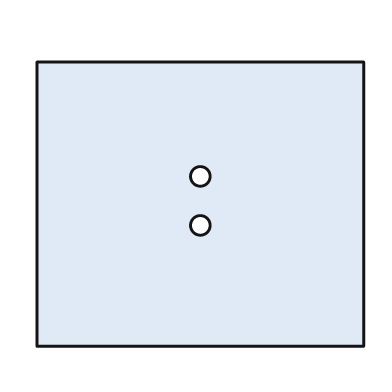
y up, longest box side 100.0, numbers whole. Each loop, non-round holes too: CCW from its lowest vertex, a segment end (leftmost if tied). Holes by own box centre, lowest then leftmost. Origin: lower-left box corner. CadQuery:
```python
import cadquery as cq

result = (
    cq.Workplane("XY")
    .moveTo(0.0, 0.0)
    .lineTo(100.0, 0.0)
    .lineTo(100.0, 87.0)
    .lineTo(0.0, 87.0)
    .close()
    .moveTo(50.0, 37.0)
    .circle(3.0)
    .moveTo(50.0, 52.0)
    .circle(3.0)
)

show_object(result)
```